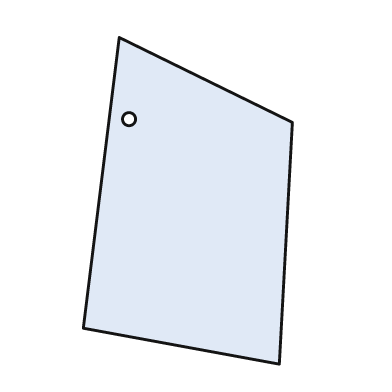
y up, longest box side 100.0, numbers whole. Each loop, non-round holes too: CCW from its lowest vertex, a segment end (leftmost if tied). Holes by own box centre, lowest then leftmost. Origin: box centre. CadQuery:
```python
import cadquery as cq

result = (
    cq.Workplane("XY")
    .moveTo(28.0, -50.0)
    .lineTo(32.0, 24.0)
    .lineTo(-21.0, 50.0)
    .lineTo(-32.0, -39.0)
    .close()
    .moveTo(-18.0, 25.0)
    .circle(2.0)
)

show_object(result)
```